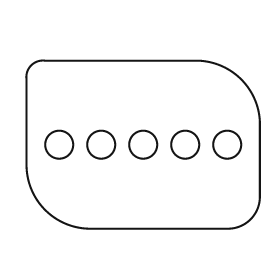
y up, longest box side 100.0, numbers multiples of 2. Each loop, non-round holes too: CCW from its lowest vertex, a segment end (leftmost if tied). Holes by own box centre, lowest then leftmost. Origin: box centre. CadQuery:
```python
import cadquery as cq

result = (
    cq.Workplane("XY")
    .moveTo(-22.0, -36.0)
    .lineTo(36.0, -36.0)
    .threePointArc((46.0, -32.0), (50.0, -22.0))
    .lineTo(50.0, 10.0)
    .threePointArc((42.0, 28.0), (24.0, 36.0))
    .lineTo(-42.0, 36.0)
    .threePointArc((-48.0, 34.0), (-50.0, 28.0))
    .lineTo(-50.0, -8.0)
    .threePointArc((-42.0, -28.0), (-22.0, -36.0))
    .close()
    .moveTo(-36.0, 0.0)
    .circle(6.0)
    .moveTo(-18.0, 0.0)
    .circle(6.0)
    .moveTo(0.0, 0.0)
    .circle(6.0)
    .moveTo(18.0, 0.0)
    .circle(6.0)
    .moveTo(36.0, 0.0)
    .circle(6.0)
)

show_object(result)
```